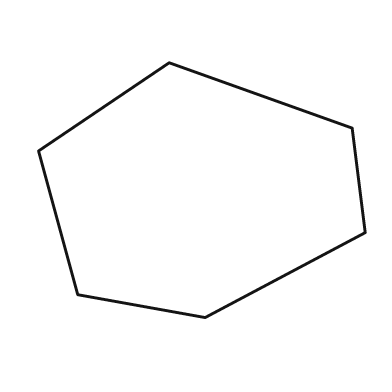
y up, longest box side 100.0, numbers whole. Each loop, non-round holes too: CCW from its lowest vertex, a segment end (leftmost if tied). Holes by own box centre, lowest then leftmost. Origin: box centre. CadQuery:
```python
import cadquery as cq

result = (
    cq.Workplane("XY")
    .moveTo(1.0, -39.0)
    .lineTo(50.0, -13.0)
    .lineTo(46.0, 19.0)
    .lineTo(-10.0, 39.0)
    .lineTo(-50.0, 12.0)
    .lineTo(-38.0, -32.0)
    .close()
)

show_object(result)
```